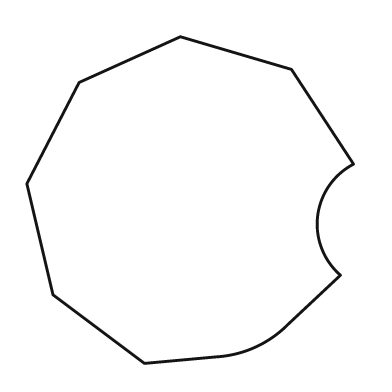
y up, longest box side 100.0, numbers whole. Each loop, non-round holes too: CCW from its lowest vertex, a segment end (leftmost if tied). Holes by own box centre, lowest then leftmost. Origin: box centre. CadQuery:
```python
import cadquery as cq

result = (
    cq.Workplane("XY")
    .moveTo(-14.0, -50.0)
    .lineTo(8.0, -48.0)
    .threePointArc((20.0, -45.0), (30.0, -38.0))
    .lineTo(46.0, -23.0)
    .threePointArc((39.0, -5.0), (50.0, 11.0))
    .lineTo(31.0, 40.0)
    .lineTo(-3.0, 50.0)
    .lineTo(-34.0, 36.0)
    .lineTo(-50.0, 5.0)
    .lineTo(-42.0, -29.0)
    .close()
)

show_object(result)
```